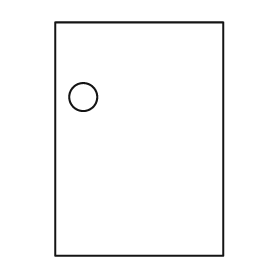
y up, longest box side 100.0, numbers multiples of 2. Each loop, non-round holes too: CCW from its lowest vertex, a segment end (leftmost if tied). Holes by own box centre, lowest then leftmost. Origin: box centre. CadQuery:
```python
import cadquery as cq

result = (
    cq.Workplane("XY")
    .moveTo(-36.0, -50.0)
    .lineTo(36.0, -50.0)
    .lineTo(36.0, 50.0)
    .lineTo(-36.0, 50.0)
    .close()
    .moveTo(-24.0, 18.0)
    .circle(6.0)
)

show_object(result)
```